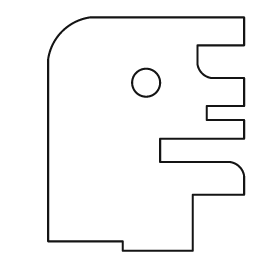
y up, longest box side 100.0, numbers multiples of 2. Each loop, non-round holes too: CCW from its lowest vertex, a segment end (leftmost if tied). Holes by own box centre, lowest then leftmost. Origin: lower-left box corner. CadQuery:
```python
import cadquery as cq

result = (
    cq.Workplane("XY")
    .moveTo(32.0, 0.0)
    .lineTo(62.0, 0.0)
    .lineTo(62.0, 24.0)
    .lineTo(84.0, 24.0)
    .lineTo(84.0, 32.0)
    .threePointArc((82.0, 36.0), (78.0, 38.0))
    .lineTo(48.0, 38.0)
    .lineTo(48.0, 48.0)
    .lineTo(84.0, 48.0)
    .lineTo(84.0, 56.0)
    .lineTo(68.0, 56.0)
    .lineTo(68.0, 62.0)
    .lineTo(84.0, 62.0)
    .lineTo(84.0, 74.0)
    .lineTo(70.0, 74.0)
    .threePointArc((66.0, 76.0), (64.0, 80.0))
    .lineTo(64.0, 88.0)
    .lineTo(84.0, 88.0)
    .lineTo(84.0, 100.0)
    .lineTo(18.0, 100.0)
    .threePointArc((6.0, 94.0), (0.0, 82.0))
    .lineTo(0.0, 4.0)
    .lineTo(32.0, 4.0)
    .close()
    .moveTo(42.0, 72.0)
    .circle(6.0)
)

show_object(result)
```